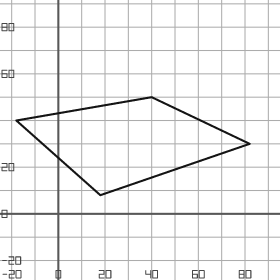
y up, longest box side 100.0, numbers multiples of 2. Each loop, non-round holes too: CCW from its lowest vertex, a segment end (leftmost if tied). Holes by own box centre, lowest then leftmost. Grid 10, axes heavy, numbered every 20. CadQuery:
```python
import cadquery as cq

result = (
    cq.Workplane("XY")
    .moveTo(18.0, 8.0)
    .lineTo(82.0, 30.0)
    .lineTo(40.0, 50.0)
    .lineTo(-18.0, 40.0)
    .close()
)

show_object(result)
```